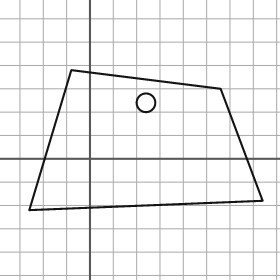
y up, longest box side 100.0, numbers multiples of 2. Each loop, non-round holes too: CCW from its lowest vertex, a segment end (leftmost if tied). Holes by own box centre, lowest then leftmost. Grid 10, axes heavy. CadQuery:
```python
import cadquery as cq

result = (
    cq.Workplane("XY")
    .moveTo(-26.0, -22.0)
    .lineTo(74.0, -18.0)
    .lineTo(56.0, 30.0)
    .lineTo(-8.0, 38.0)
    .close()
    .moveTo(24.0, 24.0)
    .circle(4.0)
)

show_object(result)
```